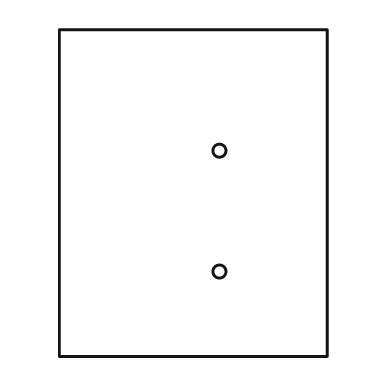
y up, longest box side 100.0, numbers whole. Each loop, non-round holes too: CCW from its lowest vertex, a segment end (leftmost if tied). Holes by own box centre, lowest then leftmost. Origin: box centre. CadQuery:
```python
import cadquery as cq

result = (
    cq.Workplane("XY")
    .moveTo(-41.0, -50.0)
    .lineTo(41.0, -50.0)
    .lineTo(41.0, 50.0)
    .lineTo(-41.0, 50.0)
    .close()
    .moveTo(8.0, -24.0)
    .circle(2.0)
    .moveTo(8.0, 13.0)
    .circle(2.0)
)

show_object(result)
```